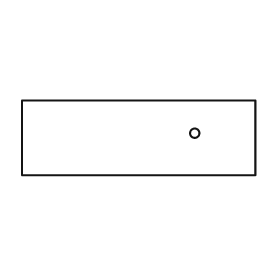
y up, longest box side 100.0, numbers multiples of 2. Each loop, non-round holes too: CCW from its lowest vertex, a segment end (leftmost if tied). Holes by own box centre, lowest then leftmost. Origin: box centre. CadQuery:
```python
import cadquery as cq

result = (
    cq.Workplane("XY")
    .moveTo(-50.0, -16.0)
    .lineTo(50.0, -16.0)
    .lineTo(50.0, 16.0)
    .lineTo(-50.0, 16.0)
    .close()
    .moveTo(24.0, 2.0)
    .circle(2.0)
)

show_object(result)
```